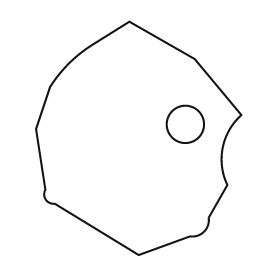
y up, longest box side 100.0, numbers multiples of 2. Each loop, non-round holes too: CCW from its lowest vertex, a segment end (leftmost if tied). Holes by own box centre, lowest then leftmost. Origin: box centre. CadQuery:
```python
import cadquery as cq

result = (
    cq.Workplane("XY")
    .moveTo(0.0, -50.0)
    .lineTo(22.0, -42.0)
    .threePointArc((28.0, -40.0), (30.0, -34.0))
    .lineTo(38.0, -20.0)
    .threePointArc((36.0, -4.0), (44.0, 10.0))
    .lineTo(24.0, 34.0)
    .lineTo(-4.0, 50.0)
    .lineTo(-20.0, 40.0)
    .threePointArc((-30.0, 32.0), (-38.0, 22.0))
    .lineTo(-44.0, 4.0)
    .lineTo(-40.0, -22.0)
    .threePointArc((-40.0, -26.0), (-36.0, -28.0))
    .close()
    .moveTo(20.0, 6.0)
    .circle(8.0)
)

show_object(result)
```